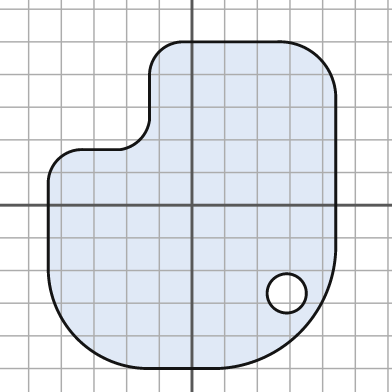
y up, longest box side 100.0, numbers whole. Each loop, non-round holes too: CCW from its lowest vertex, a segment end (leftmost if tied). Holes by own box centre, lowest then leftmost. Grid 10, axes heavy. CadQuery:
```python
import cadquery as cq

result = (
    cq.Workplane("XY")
    .moveTo(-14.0, -50.0)
    .lineTo(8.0, -50.0)
    .threePointArc((33.0, -39.0), (44.0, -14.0))
    .lineTo(44.0, 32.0)
    .threePointArc((39.0, 45.0), (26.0, 50.0))
    .lineTo(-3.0, 50.0)
    .threePointArc((-10.0, 47.0), (-13.0, 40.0))
    .lineTo(-13.0, 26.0)
    .threePointArc((-16.0, 20.0), (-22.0, 17.0))
    .lineTo(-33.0, 17.0)
    .threePointArc((-41.0, 14.0), (-44.0, 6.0))
    .lineTo(-44.0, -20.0)
    .threePointArc((-35.0, -41.0), (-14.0, -50.0))
    .close()
    .moveTo(29.0, -27.0)
    .circle(6.0)
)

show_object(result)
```